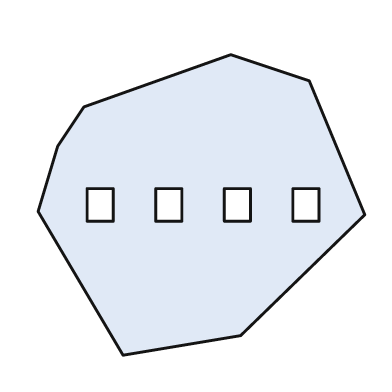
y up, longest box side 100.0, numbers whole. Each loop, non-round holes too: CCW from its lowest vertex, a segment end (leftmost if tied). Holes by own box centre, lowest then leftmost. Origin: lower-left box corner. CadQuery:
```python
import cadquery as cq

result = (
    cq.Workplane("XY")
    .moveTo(26.0, 0.0)
    .lineTo(62.0, 6.0)
    .lineTo(100.0, 43.0)
    .lineTo(83.0, 84.0)
    .lineTo(59.0, 92.0)
    .lineTo(14.0, 76.0)
    .lineTo(6.0, 64.0)
    .lineTo(0.0, 44.0)
    .close()
    .moveTo(15.0, 41.0)
    .lineTo(23.0, 41.0)
    .lineTo(23.0, 51.0)
    .lineTo(15.0, 51.0)
    .close()
    .moveTo(36.0, 41.0)
    .lineTo(44.0, 41.0)
    .lineTo(44.0, 51.0)
    .lineTo(36.0, 51.0)
    .close()
    .moveTo(57.0, 41.0)
    .lineTo(65.0, 41.0)
    .lineTo(65.0, 51.0)
    .lineTo(57.0, 51.0)
    .close()
    .moveTo(78.0, 41.0)
    .lineTo(86.0, 41.0)
    .lineTo(86.0, 51.0)
    .lineTo(78.0, 51.0)
    .close()
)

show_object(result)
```